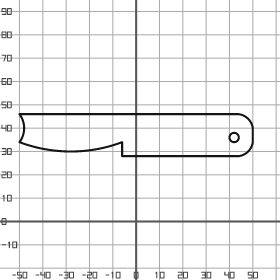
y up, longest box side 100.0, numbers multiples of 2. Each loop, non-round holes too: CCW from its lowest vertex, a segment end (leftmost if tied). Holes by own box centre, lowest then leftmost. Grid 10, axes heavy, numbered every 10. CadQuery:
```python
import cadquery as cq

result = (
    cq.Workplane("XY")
    .moveTo(-6.0, 28.0)
    .lineTo(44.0, 28.0)
    .threePointArc((48.0, 30.0), (50.0, 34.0))
    .lineTo(50.0, 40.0)
    .threePointArc((48.0, 44.0), (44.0, 46.0))
    .lineTo(-50.0, 46.0)
    .threePointArc((-48.0, 40.0), (-50.0, 34.0))
    .threePointArc((-28.0, 30.0), (-6.0, 34.0))
    .close()
    .moveTo(42.0, 36.0)
    .circle(2.0)
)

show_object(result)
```